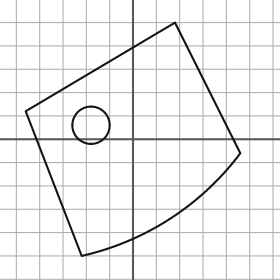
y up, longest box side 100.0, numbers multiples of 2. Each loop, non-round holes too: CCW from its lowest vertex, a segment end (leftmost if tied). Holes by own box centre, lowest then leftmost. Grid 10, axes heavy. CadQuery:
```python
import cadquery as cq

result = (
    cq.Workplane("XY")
    .moveTo(-22.0, -50.0)
    .threePointArc((16.0, -34.0), (46.0, -6.0))
    .lineTo(18.0, 50.0)
    .lineTo(-46.0, 12.0)
    .close()
    .moveTo(-18.0, 6.0)
    .circle(8.0)
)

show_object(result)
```